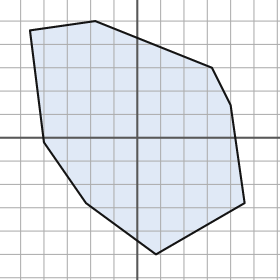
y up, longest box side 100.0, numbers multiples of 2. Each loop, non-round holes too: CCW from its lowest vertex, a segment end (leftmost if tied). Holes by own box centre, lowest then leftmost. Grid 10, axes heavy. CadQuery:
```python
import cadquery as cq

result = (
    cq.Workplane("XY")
    .moveTo(8.0, -50.0)
    .lineTo(46.0, -28.0)
    .lineTo(40.0, 14.0)
    .lineTo(32.0, 30.0)
    .lineTo(-18.0, 50.0)
    .lineTo(-46.0, 46.0)
    .lineTo(-40.0, -2.0)
    .lineTo(-22.0, -28.0)
    .close()
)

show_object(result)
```